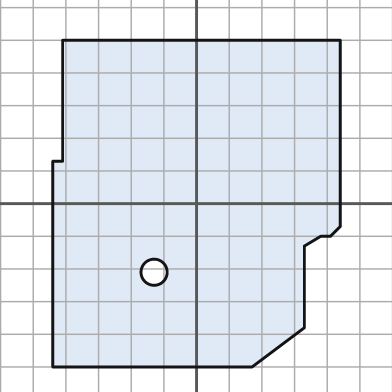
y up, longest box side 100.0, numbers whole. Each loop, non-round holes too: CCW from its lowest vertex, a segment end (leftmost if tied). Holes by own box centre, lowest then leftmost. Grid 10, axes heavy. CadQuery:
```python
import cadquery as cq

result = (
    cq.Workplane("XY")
    .moveTo(-44.0, -50.0)
    .lineTo(17.0, -50.0)
    .lineTo(33.0, -38.0)
    .lineTo(33.0, -13.0)
    .lineTo(38.0, -10.0)
    .lineTo(41.0, -10.0)
    .lineTo(44.0, -7.0)
    .lineTo(44.0, 50.0)
    .lineTo(-41.0, 50.0)
    .lineTo(-41.0, 13.0)
    .lineTo(-44.0, 13.0)
    .close()
    .moveTo(-13.0, -21.0)
    .circle(4.0)
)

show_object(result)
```